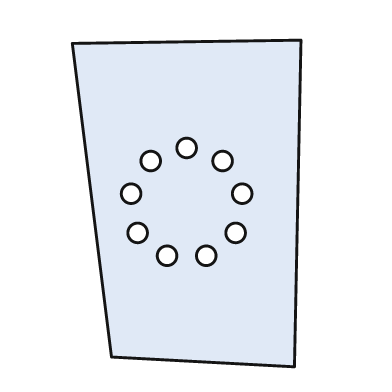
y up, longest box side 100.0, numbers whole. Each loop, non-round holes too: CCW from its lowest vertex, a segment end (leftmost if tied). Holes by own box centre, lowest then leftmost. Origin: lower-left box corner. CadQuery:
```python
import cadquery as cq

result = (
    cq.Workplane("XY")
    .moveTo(68.0, 0.0)
    .lineTo(70.0, 100.0)
    .lineTo(0.0, 99.0)
    .lineTo(12.0, 3.0)
    .close()
    .moveTo(29.0, 34.0)
    .circle(3.0)
    .moveTo(41.0, 34.0)
    .circle(3.0)
    .moveTo(20.0, 41.0)
    .circle(3.0)
    .moveTo(50.0, 41.0)
    .circle(3.0)
    .moveTo(18.0, 53.0)
    .circle(3.0)
    .moveTo(52.0, 53.0)
    .circle(3.0)
    .moveTo(24.0, 63.0)
    .circle(3.0)
    .moveTo(46.0, 63.0)
    .circle(3.0)
    .moveTo(35.0, 67.0)
    .circle(3.0)
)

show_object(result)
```